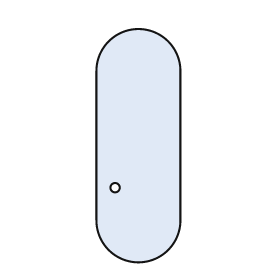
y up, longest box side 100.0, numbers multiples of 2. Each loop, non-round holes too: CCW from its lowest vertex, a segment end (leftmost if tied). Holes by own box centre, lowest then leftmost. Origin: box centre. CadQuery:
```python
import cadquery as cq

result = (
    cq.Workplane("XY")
    .moveTo(-18.0, -32.0)
    .threePointArc((0.0, -50.0), (18.0, -32.0))
    .lineTo(18.0, 32.0)
    .threePointArc((0.0, 50.0), (-18.0, 32.0))
    .close()
    .moveTo(-10.0, -18.0)
    .circle(2.0)
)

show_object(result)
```